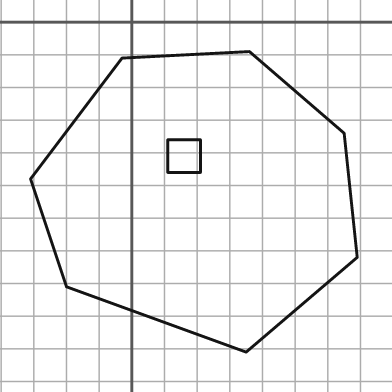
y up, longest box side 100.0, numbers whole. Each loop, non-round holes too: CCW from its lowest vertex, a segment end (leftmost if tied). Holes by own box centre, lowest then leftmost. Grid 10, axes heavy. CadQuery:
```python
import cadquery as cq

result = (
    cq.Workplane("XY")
    .moveTo(35.0, -101.0)
    .lineTo(69.0, -72.0)
    .lineTo(65.0, -34.0)
    .lineTo(36.0, -9.0)
    .lineTo(-3.0, -11.0)
    .lineTo(-31.0, -48.0)
    .lineTo(-20.0, -81.0)
    .close()
    .moveTo(11.0, -46.0)
    .lineTo(21.0, -46.0)
    .lineTo(21.0, -36.0)
    .lineTo(11.0, -36.0)
    .close()
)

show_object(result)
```